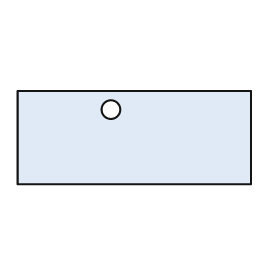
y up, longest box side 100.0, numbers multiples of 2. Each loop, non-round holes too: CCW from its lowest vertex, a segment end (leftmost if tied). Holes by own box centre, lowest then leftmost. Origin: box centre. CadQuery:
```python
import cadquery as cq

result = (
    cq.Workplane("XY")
    .moveTo(-50.0, -20.0)
    .lineTo(50.0, -20.0)
    .lineTo(50.0, 20.0)
    .lineTo(-50.0, 20.0)
    .close()
    .moveTo(-10.0, 12.0)
    .circle(4.0)
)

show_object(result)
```